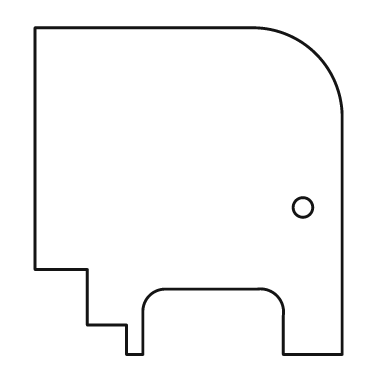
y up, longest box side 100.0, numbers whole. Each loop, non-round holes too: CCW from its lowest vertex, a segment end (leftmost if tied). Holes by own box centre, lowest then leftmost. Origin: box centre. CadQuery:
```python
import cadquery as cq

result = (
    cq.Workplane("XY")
    .moveTo(-19.0, -50.0)
    .lineTo(-14.0, -50.0)
    .lineTo(-14.0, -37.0)
    .threePointArc((-12.0, -32.0), (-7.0, -30.0))
    .lineTo(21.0, -30.0)
    .threePointArc((27.0, -32.0), (29.0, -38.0))
    .lineTo(29.0, -50.0)
    .lineTo(47.0, -50.0)
    .lineTo(47.0, 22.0)
    .threePointArc((39.0, 42.0), (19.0, 50.0))
    .lineTo(-47.0, 50.0)
    .lineTo(-47.0, -24.0)
    .lineTo(-31.0, -24.0)
    .lineTo(-31.0, -41.0)
    .lineTo(-19.0, -41.0)
    .close()
    .moveTo(35.0, -5.0)
    .circle(3.0)
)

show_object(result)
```